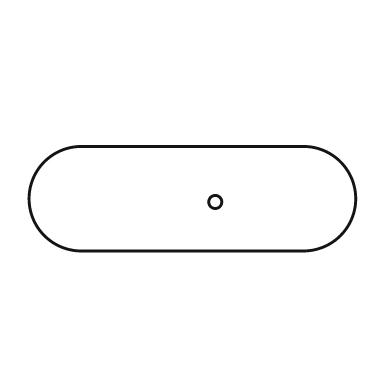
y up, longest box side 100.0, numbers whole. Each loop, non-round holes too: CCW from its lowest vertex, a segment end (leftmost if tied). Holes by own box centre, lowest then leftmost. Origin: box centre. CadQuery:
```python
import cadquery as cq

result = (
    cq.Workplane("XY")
    .moveTo(-34.0, -16.0)
    .lineTo(34.0, -16.0)
    .threePointArc((50.0, 0.0), (34.0, 16.0))
    .lineTo(-34.0, 16.0)
    .threePointArc((-50.0, 0.0), (-34.0, -16.0))
    .close()
    .moveTo(7.0, -1.0)
    .circle(2.0)
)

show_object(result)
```